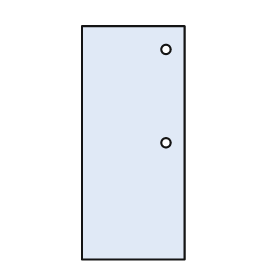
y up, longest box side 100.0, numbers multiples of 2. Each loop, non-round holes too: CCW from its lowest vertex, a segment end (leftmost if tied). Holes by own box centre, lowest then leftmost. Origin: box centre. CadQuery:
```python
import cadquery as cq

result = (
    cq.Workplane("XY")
    .moveTo(-22.0, -50.0)
    .lineTo(22.0, -50.0)
    .lineTo(22.0, 50.0)
    .lineTo(-22.0, 50.0)
    .close()
    .moveTo(14.0, 0.0)
    .circle(2.0)
    .moveTo(14.0, 40.0)
    .circle(2.0)
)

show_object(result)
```